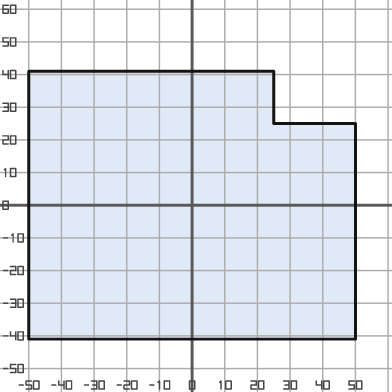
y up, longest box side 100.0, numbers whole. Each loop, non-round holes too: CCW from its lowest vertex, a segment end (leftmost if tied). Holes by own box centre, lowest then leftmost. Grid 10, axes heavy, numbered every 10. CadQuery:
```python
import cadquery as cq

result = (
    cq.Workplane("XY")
    .moveTo(-50.0, -41.0)
    .lineTo(50.0, -41.0)
    .lineTo(50.0, 25.0)
    .lineTo(25.0, 25.0)
    .lineTo(25.0, 41.0)
    .lineTo(-50.0, 41.0)
    .close()
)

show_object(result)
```